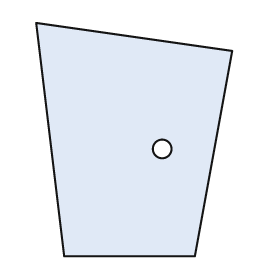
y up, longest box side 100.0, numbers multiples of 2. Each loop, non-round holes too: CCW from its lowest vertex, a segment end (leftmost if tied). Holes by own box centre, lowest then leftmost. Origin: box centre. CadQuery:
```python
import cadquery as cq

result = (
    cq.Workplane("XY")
    .moveTo(-30.0, -50.0)
    .lineTo(26.0, -50.0)
    .lineTo(42.0, 38.0)
    .lineTo(-42.0, 50.0)
    .close()
    .moveTo(12.0, -4.0)
    .circle(4.0)
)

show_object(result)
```